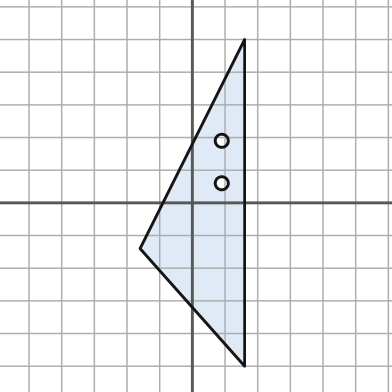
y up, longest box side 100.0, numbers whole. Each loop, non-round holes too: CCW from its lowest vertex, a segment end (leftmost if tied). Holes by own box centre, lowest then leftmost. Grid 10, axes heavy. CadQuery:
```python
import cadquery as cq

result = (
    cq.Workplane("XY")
    .moveTo(16.0, -50.0)
    .lineTo(16.0, 50.0)
    .lineTo(-16.0, -14.0)
    .close()
    .moveTo(9.0, 6.0)
    .circle(2.0)
    .moveTo(9.0, 19.0)
    .circle(2.0)
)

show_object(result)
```